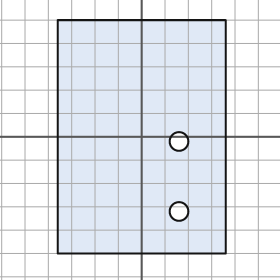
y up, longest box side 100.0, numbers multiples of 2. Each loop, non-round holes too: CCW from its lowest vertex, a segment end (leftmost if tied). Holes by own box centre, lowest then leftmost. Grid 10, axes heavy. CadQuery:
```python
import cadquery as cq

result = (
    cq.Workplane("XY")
    .moveTo(-36.0, -50.0)
    .lineTo(36.0, -50.0)
    .lineTo(36.0, 50.0)
    .lineTo(-36.0, 50.0)
    .close()
    .moveTo(16.0, -32.0)
    .circle(4.0)
    .moveTo(16.0, -2.0)
    .circle(4.0)
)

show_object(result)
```